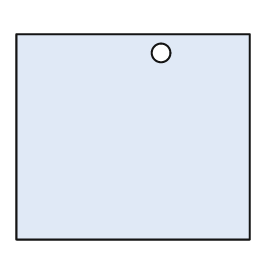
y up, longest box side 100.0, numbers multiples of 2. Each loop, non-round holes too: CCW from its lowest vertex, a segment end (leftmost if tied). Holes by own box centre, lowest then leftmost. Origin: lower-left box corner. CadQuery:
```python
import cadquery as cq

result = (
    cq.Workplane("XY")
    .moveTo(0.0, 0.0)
    .lineTo(100.0, 0.0)
    .lineTo(100.0, 88.0)
    .lineTo(0.0, 88.0)
    .close()
    .moveTo(62.0, 80.0)
    .circle(4.0)
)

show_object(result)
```